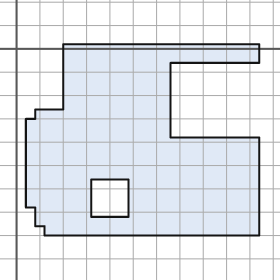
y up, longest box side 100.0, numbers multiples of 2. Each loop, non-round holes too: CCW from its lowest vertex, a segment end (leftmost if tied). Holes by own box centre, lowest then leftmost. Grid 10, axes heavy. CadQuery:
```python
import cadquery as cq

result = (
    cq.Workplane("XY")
    .moveTo(12.0, -80.0)
    .lineTo(104.0, -80.0)
    .lineTo(104.0, -38.0)
    .lineTo(66.0, -38.0)
    .lineTo(66.0, -6.0)
    .lineTo(104.0, -6.0)
    .lineTo(104.0, 2.0)
    .lineTo(20.0, 2.0)
    .lineTo(20.0, -26.0)
    .lineTo(8.0, -26.0)
    .lineTo(8.0, -30.0)
    .lineTo(4.0, -30.0)
    .lineTo(4.0, -68.0)
    .lineTo(8.0, -68.0)
    .lineTo(8.0, -76.0)
    .lineTo(12.0, -76.0)
    .close()
    .moveTo(32.0, -72.0)
    .lineTo(48.0, -72.0)
    .lineTo(48.0, -56.0)
    .lineTo(32.0, -56.0)
    .close()
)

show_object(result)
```